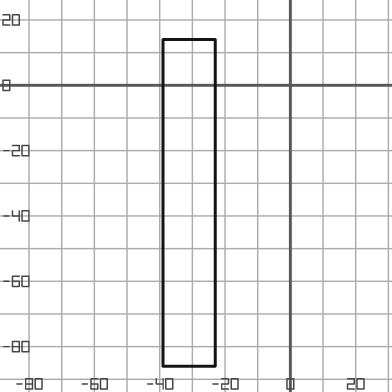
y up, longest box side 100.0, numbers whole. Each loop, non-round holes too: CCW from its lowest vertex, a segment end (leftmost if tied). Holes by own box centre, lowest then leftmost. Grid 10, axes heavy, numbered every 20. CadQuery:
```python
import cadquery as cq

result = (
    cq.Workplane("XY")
    .moveTo(-39.0, -86.0)
    .lineTo(-23.0, -86.0)
    .lineTo(-23.0, 14.0)
    .lineTo(-39.0, 14.0)
    .close()
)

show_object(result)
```